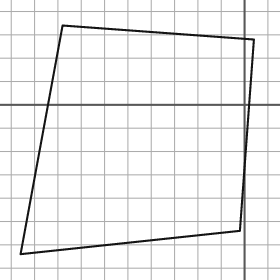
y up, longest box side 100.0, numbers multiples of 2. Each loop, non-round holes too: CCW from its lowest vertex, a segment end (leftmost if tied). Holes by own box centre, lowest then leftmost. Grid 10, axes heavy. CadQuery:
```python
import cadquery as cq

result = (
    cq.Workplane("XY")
    .moveTo(-96.0, -64.0)
    .lineTo(-2.0, -54.0)
    .lineTo(4.0, 28.0)
    .lineTo(-78.0, 34.0)
    .close()
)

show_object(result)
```